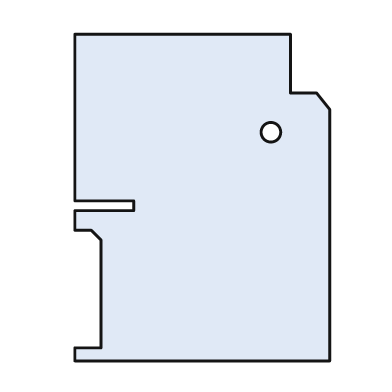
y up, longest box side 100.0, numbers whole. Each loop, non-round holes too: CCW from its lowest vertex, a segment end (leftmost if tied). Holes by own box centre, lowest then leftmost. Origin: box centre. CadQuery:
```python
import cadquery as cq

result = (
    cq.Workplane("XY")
    .moveTo(-39.0, -50.0)
    .lineTo(39.0, -50.0)
    .lineTo(39.0, 27.0)
    .lineTo(35.0, 32.0)
    .lineTo(27.0, 32.0)
    .lineTo(27.0, 50.0)
    .lineTo(-39.0, 50.0)
    .lineTo(-39.0, -1.0)
    .lineTo(-21.0, -1.0)
    .lineTo(-21.0, -4.0)
    .lineTo(-39.0, -4.0)
    .lineTo(-39.0, -10.0)
    .lineTo(-34.0, -10.0)
    .lineTo(-31.0, -13.0)
    .lineTo(-31.0, -46.0)
    .lineTo(-39.0, -46.0)
    .close()
    .moveTo(21.0, 20.0)
    .circle(3.0)
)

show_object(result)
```